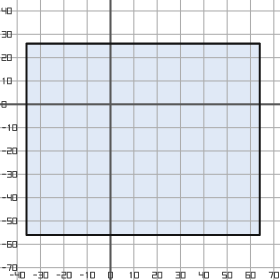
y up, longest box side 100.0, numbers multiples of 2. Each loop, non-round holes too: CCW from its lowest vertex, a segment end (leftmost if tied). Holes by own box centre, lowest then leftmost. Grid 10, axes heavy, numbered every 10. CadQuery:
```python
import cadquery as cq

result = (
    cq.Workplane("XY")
    .moveTo(-36.0, -56.0)
    .lineTo(64.0, -56.0)
    .lineTo(64.0, 26.0)
    .lineTo(-36.0, 26.0)
    .close()
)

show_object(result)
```